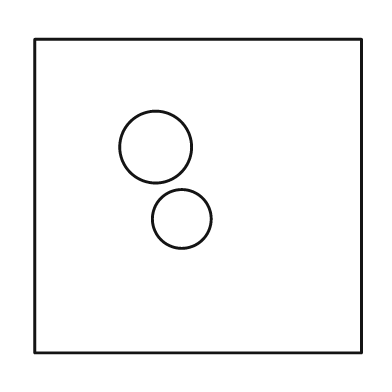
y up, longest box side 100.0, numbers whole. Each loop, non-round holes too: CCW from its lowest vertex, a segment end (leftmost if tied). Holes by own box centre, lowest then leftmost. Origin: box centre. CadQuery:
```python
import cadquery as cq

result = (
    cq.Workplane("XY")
    .moveTo(-50.0, -48.0)
    .lineTo(50.0, -48.0)
    .lineTo(50.0, 48.0)
    .lineTo(-50.0, 48.0)
    .close()
    .moveTo(-5.0, -7.0)
    .circle(9.0)
    .moveTo(-13.0, 15.0)
    .circle(11.0)
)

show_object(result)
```